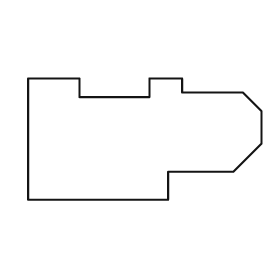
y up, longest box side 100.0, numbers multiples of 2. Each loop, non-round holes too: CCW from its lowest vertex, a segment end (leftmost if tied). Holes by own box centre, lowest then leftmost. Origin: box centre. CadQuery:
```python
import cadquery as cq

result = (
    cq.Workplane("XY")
    .moveTo(-50.0, -26.0)
    .lineTo(10.0, -26.0)
    .lineTo(10.0, -14.0)
    .lineTo(38.0, -14.0)
    .lineTo(50.0, -2.0)
    .lineTo(50.0, 12.0)
    .lineTo(42.0, 20.0)
    .lineTo(16.0, 20.0)
    .lineTo(16.0, 26.0)
    .lineTo(2.0, 26.0)
    .lineTo(2.0, 18.0)
    .lineTo(-28.0, 18.0)
    .lineTo(-28.0, 26.0)
    .lineTo(-50.0, 26.0)
    .close()
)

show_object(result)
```